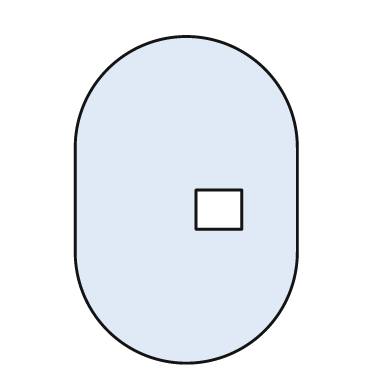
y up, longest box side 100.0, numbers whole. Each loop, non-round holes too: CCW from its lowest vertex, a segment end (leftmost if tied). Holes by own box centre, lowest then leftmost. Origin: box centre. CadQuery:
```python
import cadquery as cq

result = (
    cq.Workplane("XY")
    .moveTo(-34.0, -16.0)
    .threePointArc((0.0, -50.0), (34.0, -16.0))
    .lineTo(34.0, 16.0)
    .threePointArc((0.0, 50.0), (-34.0, 16.0))
    .close()
    .moveTo(3.0, -9.0)
    .lineTo(17.0, -9.0)
    .lineTo(17.0, 3.0)
    .lineTo(3.0, 3.0)
    .close()
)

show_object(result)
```